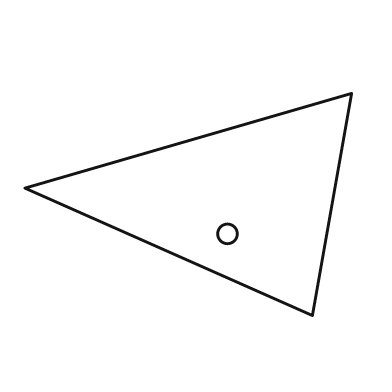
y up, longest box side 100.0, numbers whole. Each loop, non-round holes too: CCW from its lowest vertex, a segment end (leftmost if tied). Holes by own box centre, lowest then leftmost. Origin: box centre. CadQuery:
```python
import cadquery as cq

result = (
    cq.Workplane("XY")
    .moveTo(38.0, -34.0)
    .lineTo(50.0, 34.0)
    .lineTo(-50.0, 5.0)
    .close()
    .moveTo(12.0, -9.0)
    .circle(3.0)
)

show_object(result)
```